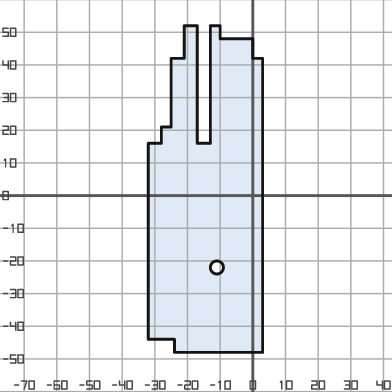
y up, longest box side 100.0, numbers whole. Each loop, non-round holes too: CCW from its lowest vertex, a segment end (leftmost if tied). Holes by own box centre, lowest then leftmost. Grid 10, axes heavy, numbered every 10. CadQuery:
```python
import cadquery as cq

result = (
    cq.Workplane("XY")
    .moveTo(-24.0, -48.0)
    .lineTo(3.0, -48.0)
    .lineTo(3.0, 42.0)
    .lineTo(0.0, 42.0)
    .lineTo(0.0, 48.0)
    .lineTo(-10.0, 48.0)
    .lineTo(-10.0, 52.0)
    .lineTo(-13.0, 52.0)
    .lineTo(-13.0, 16.0)
    .lineTo(-17.0, 16.0)
    .lineTo(-17.0, 52.0)
    .lineTo(-21.0, 52.0)
    .lineTo(-21.0, 42.0)
    .lineTo(-25.0, 42.0)
    .lineTo(-25.0, 21.0)
    .lineTo(-28.0, 21.0)
    .lineTo(-28.0, 16.0)
    .lineTo(-32.0, 16.0)
    .lineTo(-32.0, -44.0)
    .lineTo(-24.0, -44.0)
    .close()
    .moveTo(-11.0, -22.0)
    .circle(2.0)
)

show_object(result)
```